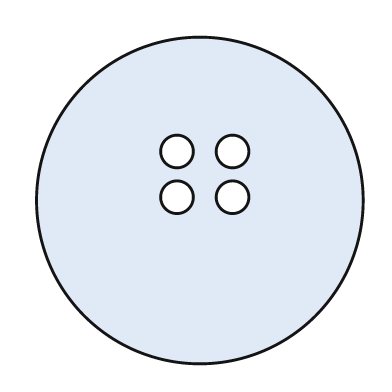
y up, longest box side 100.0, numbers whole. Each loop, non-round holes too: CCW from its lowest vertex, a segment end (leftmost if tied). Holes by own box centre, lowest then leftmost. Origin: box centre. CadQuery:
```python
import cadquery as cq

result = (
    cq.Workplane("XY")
    .moveTo(0.0, 0.0)
    .circle(50.0)
    .moveTo(-7.0, 1.0)
    .circle(5.0)
    .moveTo(10.0, 1.0)
    .circle(5.0)
    .moveTo(-7.0, 15.0)
    .circle(5.0)
    .moveTo(10.0, 15.0)
    .circle(5.0)
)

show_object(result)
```